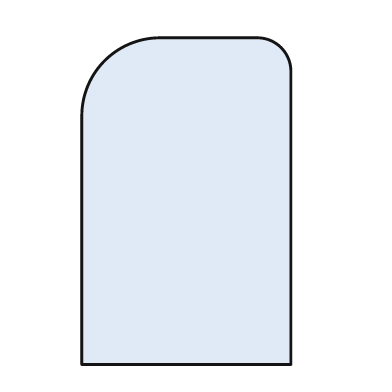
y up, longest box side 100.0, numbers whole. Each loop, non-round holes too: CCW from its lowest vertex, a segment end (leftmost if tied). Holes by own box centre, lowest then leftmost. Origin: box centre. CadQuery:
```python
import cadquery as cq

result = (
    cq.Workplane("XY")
    .moveTo(-32.0, -50.0)
    .lineTo(32.0, -50.0)
    .lineTo(32.0, 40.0)
    .threePointArc((29.0, 47.0), (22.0, 50.0))
    .lineTo(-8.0, 50.0)
    .threePointArc((-25.0, 43.0), (-32.0, 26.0))
    .close()
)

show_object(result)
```